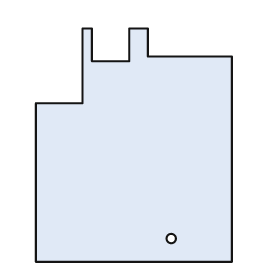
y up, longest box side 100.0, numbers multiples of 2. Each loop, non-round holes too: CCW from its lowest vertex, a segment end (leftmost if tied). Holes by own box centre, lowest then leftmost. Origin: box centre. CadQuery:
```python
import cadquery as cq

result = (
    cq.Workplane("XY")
    .moveTo(-42.0, -50.0)
    .lineTo(42.0, -50.0)
    .lineTo(42.0, 38.0)
    .lineTo(6.0, 38.0)
    .lineTo(6.0, 50.0)
    .lineTo(-2.0, 50.0)
    .lineTo(-2.0, 36.0)
    .lineTo(-18.0, 36.0)
    .lineTo(-18.0, 50.0)
    .lineTo(-22.0, 50.0)
    .lineTo(-22.0, 18.0)
    .lineTo(-42.0, 18.0)
    .close()
    .moveTo(16.0, -40.0)
    .circle(2.0)
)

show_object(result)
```